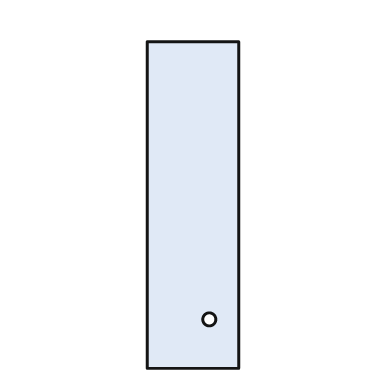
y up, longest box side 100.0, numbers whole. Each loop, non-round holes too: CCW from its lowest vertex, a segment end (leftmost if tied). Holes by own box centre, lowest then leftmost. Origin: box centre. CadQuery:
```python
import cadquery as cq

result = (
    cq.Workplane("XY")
    .moveTo(-14.0, -50.0)
    .lineTo(14.0, -50.0)
    .lineTo(14.0, 50.0)
    .lineTo(-14.0, 50.0)
    .close()
    .moveTo(5.0, -35.0)
    .circle(2.0)
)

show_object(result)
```